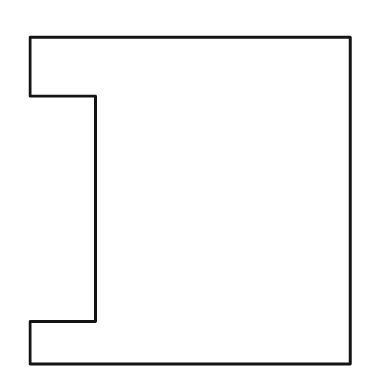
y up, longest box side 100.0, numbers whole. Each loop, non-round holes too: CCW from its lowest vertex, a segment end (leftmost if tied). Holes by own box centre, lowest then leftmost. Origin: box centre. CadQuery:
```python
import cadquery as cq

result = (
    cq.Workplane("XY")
    .moveTo(-49.0, -50.0)
    .lineTo(49.0, -50.0)
    .lineTo(49.0, 50.0)
    .lineTo(-49.0, 50.0)
    .lineTo(-49.0, 32.0)
    .lineTo(-29.0, 32.0)
    .lineTo(-29.0, -37.0)
    .lineTo(-49.0, -37.0)
    .close()
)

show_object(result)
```